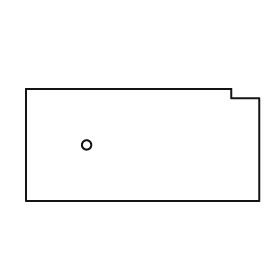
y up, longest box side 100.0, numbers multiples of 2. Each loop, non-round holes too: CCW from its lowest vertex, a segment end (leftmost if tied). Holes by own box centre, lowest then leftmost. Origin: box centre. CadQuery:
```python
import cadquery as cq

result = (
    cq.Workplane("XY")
    .moveTo(-50.0, -24.0)
    .lineTo(50.0, -24.0)
    .lineTo(50.0, 20.0)
    .lineTo(38.0, 20.0)
    .lineTo(38.0, 24.0)
    .lineTo(-50.0, 24.0)
    .close()
    .moveTo(-24.0, 0.0)
    .circle(2.0)
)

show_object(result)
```